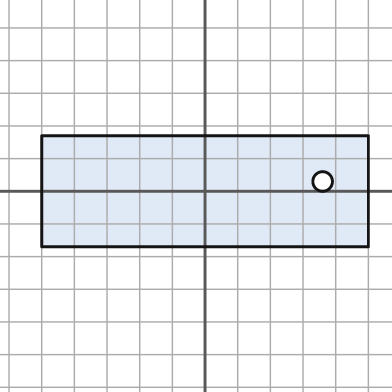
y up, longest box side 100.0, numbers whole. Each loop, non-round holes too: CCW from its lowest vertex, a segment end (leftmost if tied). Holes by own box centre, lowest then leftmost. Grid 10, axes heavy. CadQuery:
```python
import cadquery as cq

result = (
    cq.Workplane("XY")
    .moveTo(-50.0, -17.0)
    .lineTo(50.0, -17.0)
    .lineTo(50.0, 17.0)
    .lineTo(-50.0, 17.0)
    .close()
    .moveTo(36.0, 3.0)
    .circle(3.0)
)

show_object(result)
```